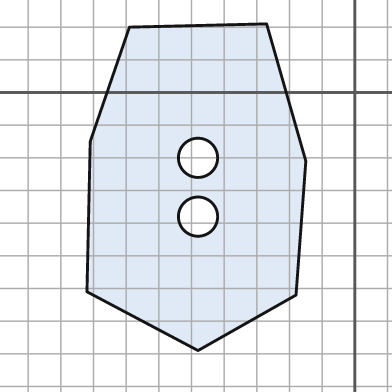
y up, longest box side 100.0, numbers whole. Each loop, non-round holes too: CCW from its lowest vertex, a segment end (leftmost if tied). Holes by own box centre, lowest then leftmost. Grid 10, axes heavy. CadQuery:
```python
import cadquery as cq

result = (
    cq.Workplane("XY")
    .moveTo(-48.0, -79.0)
    .lineTo(-18.0, -62.0)
    .lineTo(-15.0, -21.0)
    .lineTo(-27.0, 21.0)
    .lineTo(-69.0, 20.0)
    .lineTo(-81.0, -15.0)
    .lineTo(-82.0, -61.0)
    .close()
    .moveTo(-48.0, -38.0)
    .circle(6.0)
    .moveTo(-48.0, -20.0)
    .circle(6.0)
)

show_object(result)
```